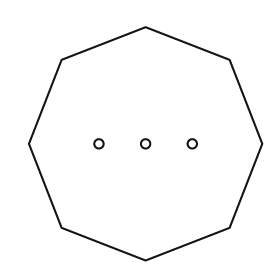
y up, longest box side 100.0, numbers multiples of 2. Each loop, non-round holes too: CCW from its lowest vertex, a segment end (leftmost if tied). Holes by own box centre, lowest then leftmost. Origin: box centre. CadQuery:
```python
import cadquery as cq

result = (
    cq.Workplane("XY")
    .moveTo(0.0, -50.0)
    .lineTo(36.0, -36.0)
    .lineTo(50.0, 0.0)
    .lineTo(36.0, 36.0)
    .lineTo(0.0, 50.0)
    .lineTo(-36.0, 36.0)
    .lineTo(-50.0, 0.0)
    .lineTo(-36.0, -36.0)
    .close()
    .moveTo(-20.0, 0.0)
    .circle(2.0)
    .moveTo(0.0, 0.0)
    .circle(2.0)
    .moveTo(20.0, 0.0)
    .circle(2.0)
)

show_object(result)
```